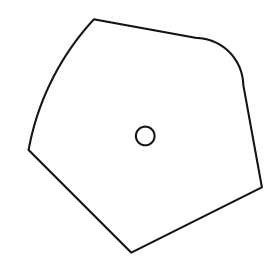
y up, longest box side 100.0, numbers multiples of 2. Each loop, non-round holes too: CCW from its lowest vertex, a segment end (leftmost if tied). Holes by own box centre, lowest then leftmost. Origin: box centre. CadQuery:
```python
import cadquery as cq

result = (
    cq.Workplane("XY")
    .moveTo(-6.0, -50.0)
    .lineTo(50.0, -22.0)
    .lineTo(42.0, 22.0)
    .threePointArc((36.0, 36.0), (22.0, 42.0))
    .lineTo(-22.0, 50.0)
    .threePointArc((-40.0, 24.0), (-50.0, -6.0))
    .close()
    .moveTo(0.0, 0.0)
    .circle(4.0)
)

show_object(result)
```